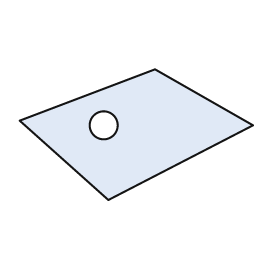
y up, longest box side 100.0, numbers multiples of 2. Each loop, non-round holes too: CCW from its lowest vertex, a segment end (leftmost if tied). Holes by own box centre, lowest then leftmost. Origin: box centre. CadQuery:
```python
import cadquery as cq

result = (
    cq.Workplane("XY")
    .moveTo(-12.0, -28.0)
    .lineTo(50.0, 4.0)
    .lineTo(8.0, 28.0)
    .lineTo(-50.0, 6.0)
    .close()
    .moveTo(-14.0, 4.0)
    .circle(6.0)
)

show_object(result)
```